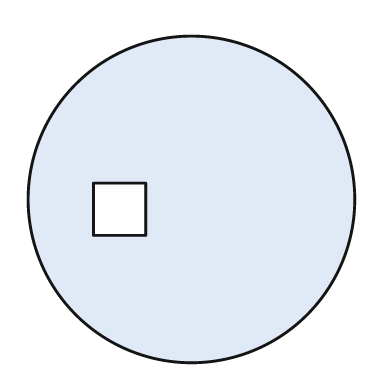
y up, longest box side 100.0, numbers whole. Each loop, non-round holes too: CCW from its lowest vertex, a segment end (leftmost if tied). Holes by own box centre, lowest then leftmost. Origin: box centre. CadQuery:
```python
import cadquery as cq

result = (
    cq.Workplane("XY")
    .moveTo(0.0, 0.0)
    .circle(50.0)
    .moveTo(-30.0, -11.0)
    .lineTo(-14.0, -11.0)
    .lineTo(-14.0, 5.0)
    .lineTo(-30.0, 5.0)
    .close()
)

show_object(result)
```